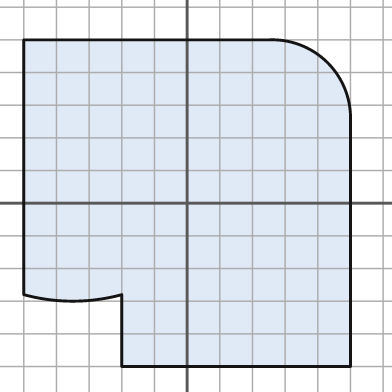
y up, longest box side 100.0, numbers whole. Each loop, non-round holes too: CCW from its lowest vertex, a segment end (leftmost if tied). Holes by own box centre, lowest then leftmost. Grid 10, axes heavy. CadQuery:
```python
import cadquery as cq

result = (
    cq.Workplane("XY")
    .moveTo(-20.0, -50.0)
    .lineTo(50.0, -50.0)
    .lineTo(50.0, 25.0)
    .threePointArc((43.0, 43.0), (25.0, 50.0))
    .lineTo(-50.0, 50.0)
    .lineTo(-50.0, -28.0)
    .threePointArc((-35.0, -30.0), (-20.0, -28.0))
    .close()
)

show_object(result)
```